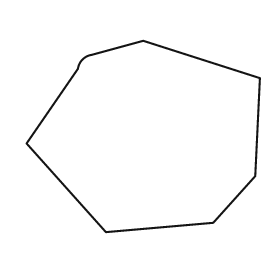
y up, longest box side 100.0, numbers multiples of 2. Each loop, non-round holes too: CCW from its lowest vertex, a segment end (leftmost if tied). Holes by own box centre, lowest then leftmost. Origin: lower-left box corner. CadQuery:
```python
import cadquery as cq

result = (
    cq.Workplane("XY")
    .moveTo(34.0, 0.0)
    .lineTo(80.0, 4.0)
    .lineTo(98.0, 24.0)
    .lineTo(100.0, 66.0)
    .lineTo(50.0, 82.0)
    .lineTo(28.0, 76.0)
    .threePointArc((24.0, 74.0), (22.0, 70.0))
    .lineTo(0.0, 38.0)
    .close()
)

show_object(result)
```